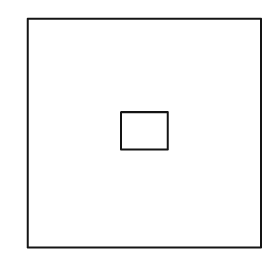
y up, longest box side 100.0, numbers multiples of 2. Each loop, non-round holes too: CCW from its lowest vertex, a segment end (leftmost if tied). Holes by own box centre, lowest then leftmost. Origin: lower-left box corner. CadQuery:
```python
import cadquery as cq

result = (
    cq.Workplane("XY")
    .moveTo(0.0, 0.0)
    .lineTo(100.0, 0.0)
    .lineTo(100.0, 98.0)
    .lineTo(0.0, 98.0)
    .close()
    .moveTo(40.0, 42.0)
    .lineTo(60.0, 42.0)
    .lineTo(60.0, 58.0)
    .lineTo(40.0, 58.0)
    .close()
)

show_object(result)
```